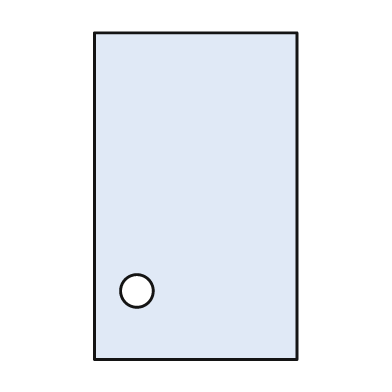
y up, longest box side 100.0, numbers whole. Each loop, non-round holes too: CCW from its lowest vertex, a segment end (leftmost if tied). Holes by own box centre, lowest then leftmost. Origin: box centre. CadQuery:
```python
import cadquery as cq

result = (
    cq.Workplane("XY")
    .moveTo(-31.0, -50.0)
    .lineTo(31.0, -50.0)
    .lineTo(31.0, 50.0)
    .lineTo(-31.0, 50.0)
    .close()
    .moveTo(-18.0, -29.0)
    .circle(5.0)
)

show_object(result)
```